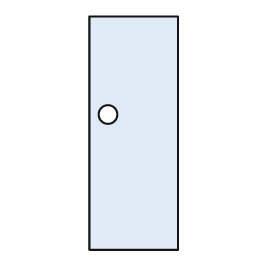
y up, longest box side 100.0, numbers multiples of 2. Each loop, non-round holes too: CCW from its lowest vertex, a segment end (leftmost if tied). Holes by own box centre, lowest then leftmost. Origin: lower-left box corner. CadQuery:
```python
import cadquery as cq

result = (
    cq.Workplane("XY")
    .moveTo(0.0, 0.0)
    .lineTo(38.0, 0.0)
    .lineTo(38.0, 100.0)
    .lineTo(0.0, 100.0)
    .close()
    .moveTo(8.0, 58.0)
    .circle(4.0)
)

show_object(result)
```